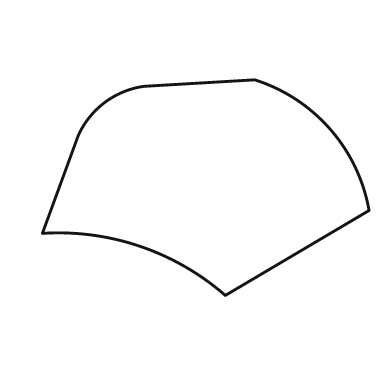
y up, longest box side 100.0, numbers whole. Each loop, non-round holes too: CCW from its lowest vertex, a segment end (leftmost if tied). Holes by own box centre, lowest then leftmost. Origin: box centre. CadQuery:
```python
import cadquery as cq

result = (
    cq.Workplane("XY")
    .moveTo(6.0, -33.0)
    .lineTo(50.0, -7.0)
    .threePointArc((38.0, 18.0), (15.0, 33.0))
    .lineTo(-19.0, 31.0)
    .threePointArc((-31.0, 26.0), (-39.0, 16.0))
    .lineTo(-50.0, -14.0)
    .threePointArc((-20.0, -18.0), (6.0, -33.0))
    .close()
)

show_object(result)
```